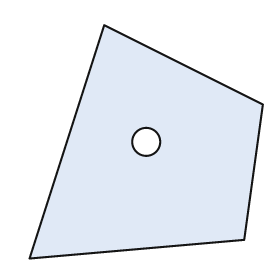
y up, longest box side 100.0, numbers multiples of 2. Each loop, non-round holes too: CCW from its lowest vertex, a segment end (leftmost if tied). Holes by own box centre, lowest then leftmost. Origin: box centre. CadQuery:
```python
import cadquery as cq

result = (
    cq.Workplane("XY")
    .moveTo(-50.0, -50.0)
    .lineTo(42.0, -42.0)
    .lineTo(50.0, 16.0)
    .lineTo(-18.0, 50.0)
    .close()
    .moveTo(0.0, 0.0)
    .circle(6.0)
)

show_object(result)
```